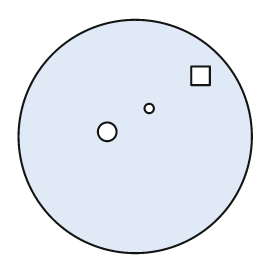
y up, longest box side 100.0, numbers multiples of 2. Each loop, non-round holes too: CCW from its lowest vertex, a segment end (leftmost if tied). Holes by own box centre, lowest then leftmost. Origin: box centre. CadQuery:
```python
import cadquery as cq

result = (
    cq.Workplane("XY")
    .moveTo(0.0, 0.0)
    .circle(50.0)
    .moveTo(-12.0, 2.0)
    .circle(4.0)
    .moveTo(6.0, 12.0)
    .circle(2.0)
    .moveTo(24.0, 22.0)
    .lineTo(32.0, 22.0)
    .lineTo(32.0, 30.0)
    .lineTo(24.0, 30.0)
    .close()
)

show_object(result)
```